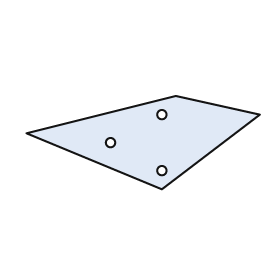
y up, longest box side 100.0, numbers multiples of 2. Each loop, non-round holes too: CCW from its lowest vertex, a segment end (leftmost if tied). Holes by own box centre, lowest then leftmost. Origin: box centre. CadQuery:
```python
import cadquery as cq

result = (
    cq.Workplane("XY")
    .moveTo(8.0, -20.0)
    .lineTo(50.0, 12.0)
    .lineTo(14.0, 20.0)
    .lineTo(-50.0, 4.0)
    .close()
    .moveTo(8.0, -12.0)
    .circle(2.0)
    .moveTo(-14.0, 0.0)
    .circle(2.0)
    .moveTo(8.0, 12.0)
    .circle(2.0)
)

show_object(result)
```